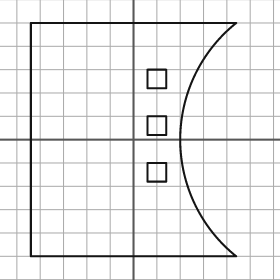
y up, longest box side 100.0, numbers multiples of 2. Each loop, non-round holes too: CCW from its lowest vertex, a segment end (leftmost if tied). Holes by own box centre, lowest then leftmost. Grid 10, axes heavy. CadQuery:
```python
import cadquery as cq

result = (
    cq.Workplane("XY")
    .moveTo(-44.0, -50.0)
    .lineTo(44.0, -50.0)
    .threePointArc((20.0, 0.0), (44.0, 50.0))
    .lineTo(-44.0, 50.0)
    .close()
    .moveTo(6.0, -18.0)
    .lineTo(14.0, -18.0)
    .lineTo(14.0, -10.0)
    .lineTo(6.0, -10.0)
    .close()
    .moveTo(6.0, 2.0)
    .lineTo(14.0, 2.0)
    .lineTo(14.0, 10.0)
    .lineTo(6.0, 10.0)
    .close()
    .moveTo(6.0, 22.0)
    .lineTo(14.0, 22.0)
    .lineTo(14.0, 30.0)
    .lineTo(6.0, 30.0)
    .close()
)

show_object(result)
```